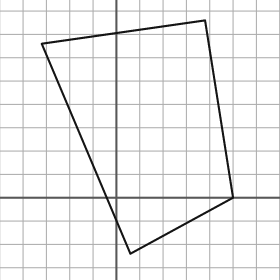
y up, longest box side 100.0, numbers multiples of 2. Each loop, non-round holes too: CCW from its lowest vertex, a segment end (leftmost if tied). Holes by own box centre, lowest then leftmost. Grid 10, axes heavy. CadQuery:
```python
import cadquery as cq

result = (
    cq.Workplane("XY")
    .moveTo(6.0, -24.0)
    .lineTo(50.0, 0.0)
    .lineTo(38.0, 76.0)
    .lineTo(-32.0, 66.0)
    .close()
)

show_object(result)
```